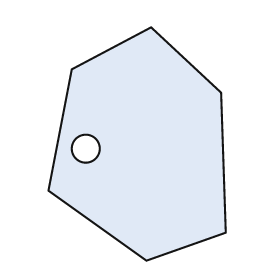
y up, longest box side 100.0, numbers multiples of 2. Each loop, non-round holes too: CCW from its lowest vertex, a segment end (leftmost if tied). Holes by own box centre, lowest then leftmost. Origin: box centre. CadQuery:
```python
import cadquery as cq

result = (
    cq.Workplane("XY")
    .moveTo(4.0, -50.0)
    .lineTo(38.0, -38.0)
    .lineTo(36.0, 22.0)
    .lineTo(6.0, 50.0)
    .lineTo(-28.0, 32.0)
    .lineTo(-38.0, -20.0)
    .close()
    .moveTo(-22.0, -2.0)
    .circle(6.0)
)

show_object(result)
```